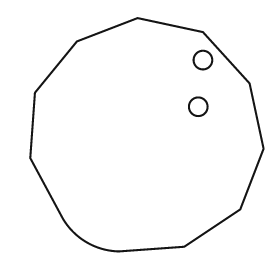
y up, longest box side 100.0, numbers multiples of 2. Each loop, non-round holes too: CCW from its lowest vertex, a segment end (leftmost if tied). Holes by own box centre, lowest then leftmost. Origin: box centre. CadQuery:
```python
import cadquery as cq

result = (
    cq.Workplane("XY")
    .moveTo(-12.0, -50.0)
    .lineTo(16.0, -48.0)
    .lineTo(40.0, -32.0)
    .lineTo(50.0, -6.0)
    .lineTo(44.0, 22.0)
    .lineTo(24.0, 44.0)
    .lineTo(-4.0, 50.0)
    .lineTo(-30.0, 40.0)
    .lineTo(-48.0, 18.0)
    .lineTo(-50.0, -10.0)
    .lineTo(-36.0, -36.0)
    .threePointArc((-26.0, -46.0), (-12.0, -50.0))
    .close()
    .moveTo(22.0, 12.0)
    .circle(4.0)
    .moveTo(24.0, 32.0)
    .circle(4.0)
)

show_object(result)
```